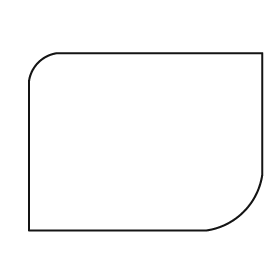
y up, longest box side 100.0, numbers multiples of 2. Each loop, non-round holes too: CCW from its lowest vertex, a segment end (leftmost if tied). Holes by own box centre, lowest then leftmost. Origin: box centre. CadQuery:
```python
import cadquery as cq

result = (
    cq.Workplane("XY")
    .moveTo(-50.0, -38.0)
    .lineTo(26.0, -38.0)
    .threePointArc((42.0, -30.0), (50.0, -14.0))
    .lineTo(50.0, 38.0)
    .lineTo(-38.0, 38.0)
    .threePointArc((-46.0, 34.0), (-50.0, 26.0))
    .close()
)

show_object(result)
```